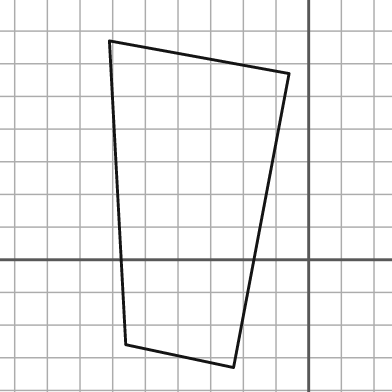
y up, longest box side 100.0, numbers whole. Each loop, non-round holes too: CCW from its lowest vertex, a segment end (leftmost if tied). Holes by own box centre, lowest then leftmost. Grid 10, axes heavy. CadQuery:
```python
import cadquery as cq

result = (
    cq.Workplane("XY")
    .moveTo(-23.0, -33.0)
    .lineTo(-6.0, 57.0)
    .lineTo(-61.0, 67.0)
    .lineTo(-56.0, -26.0)
    .close()
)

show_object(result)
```